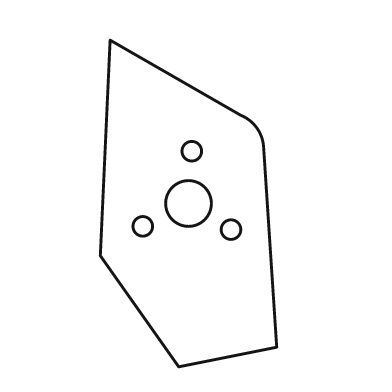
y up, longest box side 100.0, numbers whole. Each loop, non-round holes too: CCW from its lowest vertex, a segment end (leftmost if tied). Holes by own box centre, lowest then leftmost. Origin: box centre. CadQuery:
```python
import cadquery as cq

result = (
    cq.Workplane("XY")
    .moveTo(-3.0, -50.0)
    .lineTo(27.0, -44.0)
    .lineTo(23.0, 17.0)
    .threePointArc((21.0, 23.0), (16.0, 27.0))
    .lineTo(-24.0, 50.0)
    .lineTo(-27.0, -16.0)
    .close()
    .moveTo(13.0, -8.0)
    .circle(3.0)
    .moveTo(-14.0, -7.0)
    .circle(3.0)
    .moveTo(0.0, 0.0)
    .circle(7.0)
    .moveTo(1.0, 16.0)
    .circle(3.0)
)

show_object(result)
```